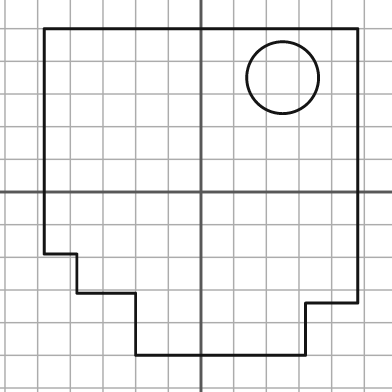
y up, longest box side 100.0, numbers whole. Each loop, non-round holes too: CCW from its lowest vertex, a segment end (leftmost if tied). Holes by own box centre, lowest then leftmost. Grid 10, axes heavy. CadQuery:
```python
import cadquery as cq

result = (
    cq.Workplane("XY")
    .moveTo(-20.0, -50.0)
    .lineTo(32.0, -50.0)
    .lineTo(32.0, -34.0)
    .lineTo(48.0, -34.0)
    .lineTo(48.0, 50.0)
    .lineTo(-48.0, 50.0)
    .lineTo(-48.0, -19.0)
    .lineTo(-38.0, -19.0)
    .lineTo(-38.0, -31.0)
    .lineTo(-20.0, -31.0)
    .close()
    .moveTo(25.0, 35.0)
    .circle(11.0)
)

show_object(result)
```